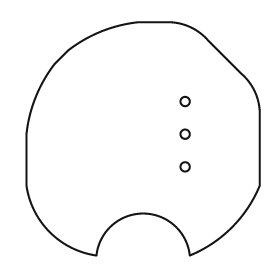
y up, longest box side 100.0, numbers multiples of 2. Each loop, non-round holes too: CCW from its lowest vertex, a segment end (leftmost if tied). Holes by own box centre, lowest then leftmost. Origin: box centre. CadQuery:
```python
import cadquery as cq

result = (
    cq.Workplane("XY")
    .moveTo(-20.0, -50.0)
    .threePointArc((0.0, -32.0), (20.0, -50.0))
    .threePointArc((38.0, -38.0), (50.0, -20.0))
    .lineTo(50.0, 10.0)
    .threePointArc((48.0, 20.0), (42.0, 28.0))
    .lineTo(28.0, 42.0)
    .threePointArc((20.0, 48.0), (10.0, 50.0))
    .lineTo(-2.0, 50.0)
    .threePointArc((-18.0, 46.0), (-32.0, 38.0))
    .lineTo(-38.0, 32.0)
    .threePointArc((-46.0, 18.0), (-50.0, 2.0))
    .lineTo(-50.0, -20.0)
    .threePointArc((-40.0, -40.0), (-20.0, -50.0))
    .close()
    .moveTo(18.0, -12.0)
    .circle(2.0)
    .moveTo(18.0, 2.0)
    .circle(2.0)
    .moveTo(18.0, 16.0)
    .circle(2.0)
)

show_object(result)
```